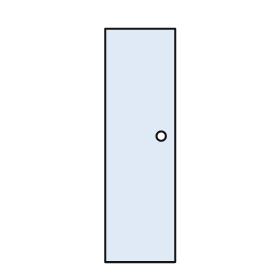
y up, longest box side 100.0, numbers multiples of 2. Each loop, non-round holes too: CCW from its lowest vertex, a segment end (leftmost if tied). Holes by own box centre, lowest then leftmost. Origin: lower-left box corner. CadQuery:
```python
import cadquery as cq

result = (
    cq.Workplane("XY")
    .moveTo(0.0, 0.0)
    .lineTo(30.0, 0.0)
    .lineTo(30.0, 100.0)
    .lineTo(0.0, 100.0)
    .close()
    .moveTo(24.0, 54.0)
    .circle(2.0)
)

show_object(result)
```